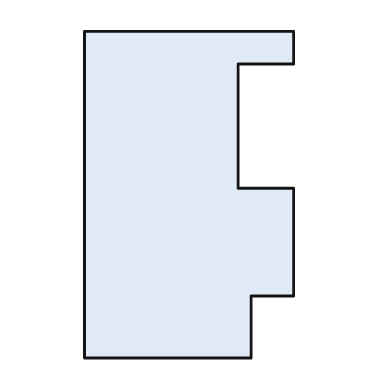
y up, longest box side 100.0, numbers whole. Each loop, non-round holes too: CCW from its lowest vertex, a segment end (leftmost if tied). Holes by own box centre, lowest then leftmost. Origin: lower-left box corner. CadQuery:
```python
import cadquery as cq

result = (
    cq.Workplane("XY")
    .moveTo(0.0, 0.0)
    .lineTo(51.0, 0.0)
    .lineTo(51.0, 19.0)
    .lineTo(64.0, 19.0)
    .lineTo(64.0, 52.0)
    .lineTo(47.0, 52.0)
    .lineTo(47.0, 90.0)
    .lineTo(64.0, 90.0)
    .lineTo(64.0, 100.0)
    .lineTo(0.0, 100.0)
    .close()
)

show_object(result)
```